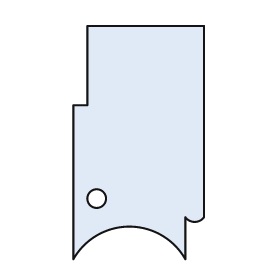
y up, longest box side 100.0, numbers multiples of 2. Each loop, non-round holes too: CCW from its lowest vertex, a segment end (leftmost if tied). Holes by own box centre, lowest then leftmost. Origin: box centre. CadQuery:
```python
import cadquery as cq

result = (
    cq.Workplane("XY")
    .moveTo(-28.0, -50.0)
    .threePointArc((-4.0, -36.0), (20.0, -50.0))
    .lineTo(20.0, -32.0)
    .threePointArc((24.0, -34.0), (28.0, -32.0))
    .lineTo(28.0, 50.0)
    .lineTo(-22.0, 50.0)
    .lineTo(-22.0, 16.0)
    .lineTo(-28.0, 16.0)
    .close()
    .moveTo(-18.0, -24.0)
    .circle(4.0)
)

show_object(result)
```